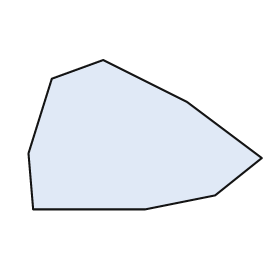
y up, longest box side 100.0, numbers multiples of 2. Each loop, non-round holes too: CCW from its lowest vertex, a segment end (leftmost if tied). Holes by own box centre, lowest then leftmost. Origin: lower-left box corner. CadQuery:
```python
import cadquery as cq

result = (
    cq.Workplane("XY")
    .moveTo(2.0, 0.0)
    .lineTo(50.0, 0.0)
    .lineTo(80.0, 6.0)
    .lineTo(100.0, 22.0)
    .lineTo(68.0, 46.0)
    .lineTo(32.0, 64.0)
    .lineTo(10.0, 56.0)
    .lineTo(0.0, 24.0)
    .close()
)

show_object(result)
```